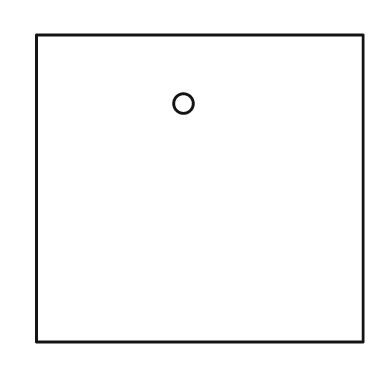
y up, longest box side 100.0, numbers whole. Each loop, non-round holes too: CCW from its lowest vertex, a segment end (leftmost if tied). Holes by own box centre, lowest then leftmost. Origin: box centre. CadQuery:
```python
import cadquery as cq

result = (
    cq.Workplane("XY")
    .moveTo(-50.0, -47.0)
    .lineTo(50.0, -47.0)
    .lineTo(50.0, 47.0)
    .lineTo(-50.0, 47.0)
    .close()
    .moveTo(-5.0, 26.0)
    .circle(3.0)
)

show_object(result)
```